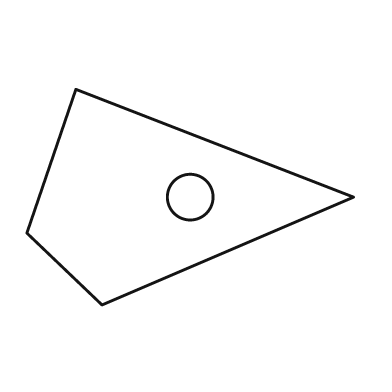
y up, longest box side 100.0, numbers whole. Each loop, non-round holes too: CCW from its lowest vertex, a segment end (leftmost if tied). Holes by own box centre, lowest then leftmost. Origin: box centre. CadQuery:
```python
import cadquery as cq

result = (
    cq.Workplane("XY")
    .moveTo(-27.0, -33.0)
    .lineTo(50.0, 0.0)
    .lineTo(-35.0, 33.0)
    .lineTo(-50.0, -11.0)
    .close()
    .moveTo(0.0, 0.0)
    .circle(7.0)
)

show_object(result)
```